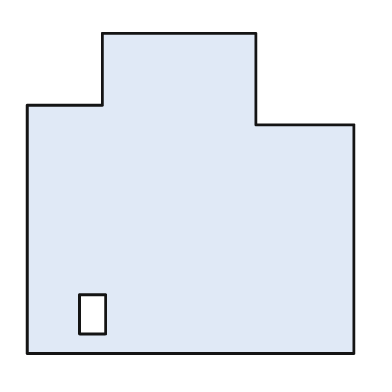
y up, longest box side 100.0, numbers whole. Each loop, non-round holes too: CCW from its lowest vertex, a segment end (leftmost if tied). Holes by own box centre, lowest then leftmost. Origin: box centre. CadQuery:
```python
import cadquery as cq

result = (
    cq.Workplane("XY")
    .moveTo(-50.0, -49.0)
    .lineTo(50.0, -49.0)
    .lineTo(50.0, 21.0)
    .lineTo(20.0, 21.0)
    .lineTo(20.0, 49.0)
    .lineTo(-27.0, 49.0)
    .lineTo(-27.0, 27.0)
    .lineTo(-50.0, 27.0)
    .close()
    .moveTo(-34.0, -43.0)
    .lineTo(-26.0, -43.0)
    .lineTo(-26.0, -31.0)
    .lineTo(-34.0, -31.0)
    .close()
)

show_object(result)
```